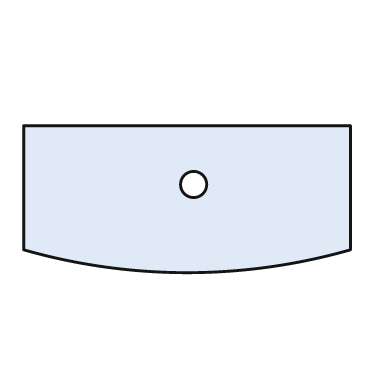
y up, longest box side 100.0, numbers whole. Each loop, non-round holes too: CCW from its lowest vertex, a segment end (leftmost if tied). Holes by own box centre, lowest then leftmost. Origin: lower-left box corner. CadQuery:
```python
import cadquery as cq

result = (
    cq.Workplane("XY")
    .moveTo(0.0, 7.0)
    .threePointArc((50.0, 0.0), (100.0, 7.0))
    .lineTo(100.0, 45.0)
    .lineTo(0.0, 45.0)
    .close()
    .moveTo(52.0, 27.0)
    .circle(4.0)
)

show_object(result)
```